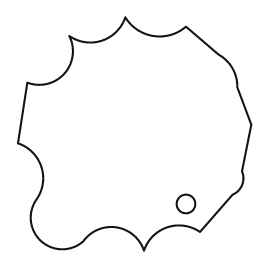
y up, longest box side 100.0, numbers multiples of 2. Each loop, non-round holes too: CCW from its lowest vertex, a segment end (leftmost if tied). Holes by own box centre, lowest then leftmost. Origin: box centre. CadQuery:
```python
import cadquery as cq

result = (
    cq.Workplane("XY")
    .moveTo(4.0, -50.0)
    .threePointArc((14.0, -40.0), (28.0, -42.0))
    .lineTo(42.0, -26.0)
    .threePointArc((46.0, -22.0), (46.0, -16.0))
    .lineTo(50.0, 4.0)
    .lineTo(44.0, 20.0)
    .threePointArc((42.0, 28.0), (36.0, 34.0))
    .lineTo(22.0, 46.0)
    .threePointArc((8.0, 42.0), (-4.0, 50.0))
    .threePointArc((-14.0, 40.0), (-28.0, 42.0))
    .threePointArc((-30.0, 26.0), (-46.0, 22.0))
    .lineTo(-50.0, -4.0)
    .threePointArc((-40.0, -14.0), (-42.0, -28.0))
    .threePointArc((-40.0, -46.0), (-22.0, -46.0))
    .threePointArc((-8.0, -40.0), (4.0, -50.0))
    .close()
    .moveTo(22.0, -30.0)
    .circle(4.0)
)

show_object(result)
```